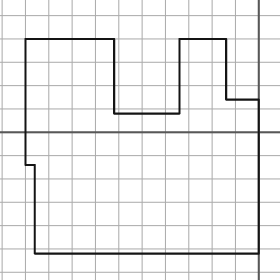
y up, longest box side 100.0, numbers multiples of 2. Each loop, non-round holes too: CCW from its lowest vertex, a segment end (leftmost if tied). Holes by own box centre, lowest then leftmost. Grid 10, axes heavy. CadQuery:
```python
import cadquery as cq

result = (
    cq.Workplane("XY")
    .moveTo(-96.0, -52.0)
    .lineTo(0.0, -52.0)
    .lineTo(0.0, 14.0)
    .lineTo(-14.0, 14.0)
    .lineTo(-14.0, 40.0)
    .lineTo(-34.0, 40.0)
    .lineTo(-34.0, 8.0)
    .lineTo(-62.0, 8.0)
    .lineTo(-62.0, 40.0)
    .lineTo(-100.0, 40.0)
    .lineTo(-100.0, -14.0)
    .lineTo(-96.0, -14.0)
    .close()
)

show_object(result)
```